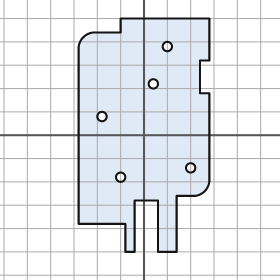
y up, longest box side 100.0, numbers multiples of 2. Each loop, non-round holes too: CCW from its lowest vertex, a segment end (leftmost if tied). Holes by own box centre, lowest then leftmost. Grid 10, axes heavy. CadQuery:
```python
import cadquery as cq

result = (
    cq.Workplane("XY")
    .moveTo(-8.0, -50.0)
    .lineTo(-4.0, -50.0)
    .lineTo(-4.0, -28.0)
    .lineTo(6.0, -28.0)
    .lineTo(6.0, -50.0)
    .lineTo(14.0, -50.0)
    .lineTo(14.0, -26.0)
    .lineTo(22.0, -26.0)
    .threePointArc((26.0, -24.0), (28.0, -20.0))
    .lineTo(28.0, 18.0)
    .lineTo(24.0, 18.0)
    .lineTo(24.0, 32.0)
    .lineTo(28.0, 32.0)
    .lineTo(28.0, 50.0)
    .lineTo(-10.0, 50.0)
    .lineTo(-10.0, 44.0)
    .lineTo(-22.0, 44.0)
    .threePointArc((-26.0, 42.0), (-28.0, 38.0))
    .lineTo(-28.0, -38.0)
    .lineTo(-8.0, -38.0)
    .close()
    .moveTo(-10.0, -18.0)
    .circle(2.0)
    .moveTo(20.0, -14.0)
    .circle(2.0)
    .moveTo(-18.0, 8.0)
    .circle(2.0)
    .moveTo(4.0, 22.0)
    .circle(2.0)
    .moveTo(10.0, 38.0)
    .circle(2.0)
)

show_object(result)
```